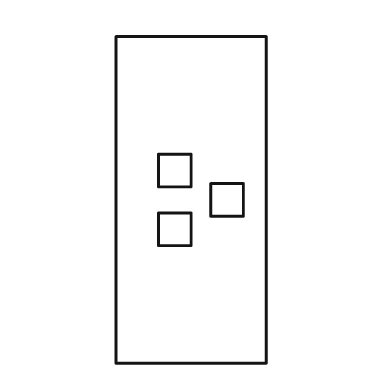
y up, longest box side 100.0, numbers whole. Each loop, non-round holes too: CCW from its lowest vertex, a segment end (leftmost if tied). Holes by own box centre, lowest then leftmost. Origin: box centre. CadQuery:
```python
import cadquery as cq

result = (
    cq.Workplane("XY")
    .moveTo(-23.0, -50.0)
    .lineTo(23.0, -50.0)
    .lineTo(23.0, 50.0)
    .lineTo(-23.0, 50.0)
    .close()
    .moveTo(-10.0, -14.0)
    .lineTo(0.0, -14.0)
    .lineTo(0.0, -4.0)
    .lineTo(-10.0, -4.0)
    .close()
    .moveTo(6.0, -5.0)
    .lineTo(16.0, -5.0)
    .lineTo(16.0, 5.0)
    .lineTo(6.0, 5.0)
    .close()
    .moveTo(-10.0, 4.0)
    .lineTo(0.0, 4.0)
    .lineTo(0.0, 14.0)
    .lineTo(-10.0, 14.0)
    .close()
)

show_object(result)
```